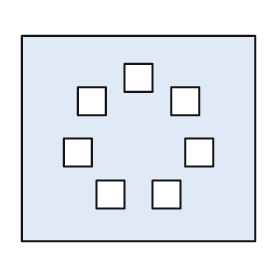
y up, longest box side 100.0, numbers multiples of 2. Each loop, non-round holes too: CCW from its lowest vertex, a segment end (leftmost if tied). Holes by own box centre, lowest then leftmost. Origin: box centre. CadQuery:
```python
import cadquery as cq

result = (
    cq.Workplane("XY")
    .moveTo(-50.0, -44.0)
    .lineTo(50.0, -44.0)
    .lineTo(50.0, 44.0)
    .lineTo(-50.0, 44.0)
    .close()
    .moveTo(-18.0, -30.0)
    .lineTo(-6.0, -30.0)
    .lineTo(-6.0, -18.0)
    .lineTo(-18.0, -18.0)
    .close()
    .moveTo(6.0, -30.0)
    .lineTo(18.0, -30.0)
    .lineTo(18.0, -18.0)
    .lineTo(6.0, -18.0)
    .close()
    .moveTo(-32.0, -12.0)
    .lineTo(-20.0, -12.0)
    .lineTo(-20.0, 0.0)
    .lineTo(-32.0, 0.0)
    .close()
    .moveTo(20.0, -12.0)
    .lineTo(32.0, -12.0)
    .lineTo(32.0, 0.0)
    .lineTo(20.0, 0.0)
    .close()
    .moveTo(-26.0, 10.0)
    .lineTo(-14.0, 10.0)
    .lineTo(-14.0, 22.0)
    .lineTo(-26.0, 22.0)
    .close()
    .moveTo(14.0, 10.0)
    .lineTo(26.0, 10.0)
    .lineTo(26.0, 22.0)
    .lineTo(14.0, 22.0)
    .close()
    .moveTo(-6.0, 20.0)
    .lineTo(6.0, 20.0)
    .lineTo(6.0, 32.0)
    .lineTo(-6.0, 32.0)
    .close()
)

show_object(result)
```